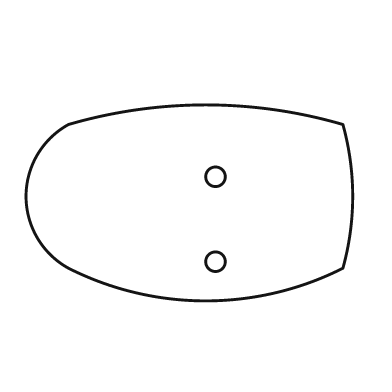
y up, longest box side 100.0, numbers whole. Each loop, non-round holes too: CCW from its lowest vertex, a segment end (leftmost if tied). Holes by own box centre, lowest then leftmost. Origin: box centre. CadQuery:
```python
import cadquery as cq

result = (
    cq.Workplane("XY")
    .moveTo(-37.0, -20.0)
    .threePointArc((5.0, -30.0), (47.0, -20.0))
    .threePointArc((50.0, 2.0), (47.0, 24.0))
    .threePointArc((5.0, 30.0), (-37.0, 24.0))
    .threePointArc((-50.0, 2.0), (-37.0, -20.0))
    .close()
    .moveTo(8.0, -18.0)
    .circle(3.0)
    .moveTo(8.0, 8.0)
    .circle(3.0)
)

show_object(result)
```